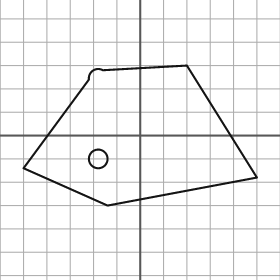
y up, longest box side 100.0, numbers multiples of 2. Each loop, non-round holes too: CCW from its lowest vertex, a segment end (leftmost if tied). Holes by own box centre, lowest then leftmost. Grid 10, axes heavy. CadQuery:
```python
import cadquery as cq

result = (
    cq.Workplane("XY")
    .moveTo(-14.0, -30.0)
    .lineTo(50.0, -18.0)
    .lineTo(20.0, 30.0)
    .lineTo(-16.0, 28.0)
    .threePointArc((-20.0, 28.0), (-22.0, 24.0))
    .lineTo(-50.0, -14.0)
    .close()
    .moveTo(-18.0, -10.0)
    .circle(4.0)
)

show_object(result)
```